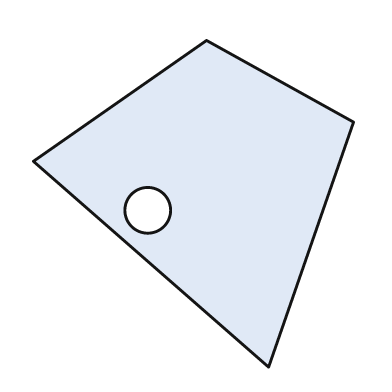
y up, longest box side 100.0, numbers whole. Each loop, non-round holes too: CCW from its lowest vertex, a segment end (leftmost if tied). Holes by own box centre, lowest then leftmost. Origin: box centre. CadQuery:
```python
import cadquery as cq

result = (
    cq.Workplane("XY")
    .moveTo(23.0, -50.0)
    .lineTo(49.0, 25.0)
    .lineTo(4.0, 50.0)
    .lineTo(-49.0, 13.0)
    .close()
    .moveTo(-14.0, -2.0)
    .circle(7.0)
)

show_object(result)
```